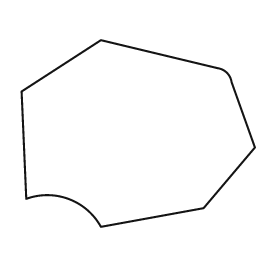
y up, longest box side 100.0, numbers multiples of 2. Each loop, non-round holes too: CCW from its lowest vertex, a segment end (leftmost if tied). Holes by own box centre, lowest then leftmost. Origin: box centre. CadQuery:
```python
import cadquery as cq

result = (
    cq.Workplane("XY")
    .moveTo(-16.0, -40.0)
    .lineTo(28.0, -32.0)
    .lineTo(50.0, -6.0)
    .lineTo(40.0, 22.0)
    .threePointArc((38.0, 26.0), (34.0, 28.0))
    .lineTo(-16.0, 40.0)
    .lineTo(-50.0, 18.0)
    .lineTo(-48.0, -28.0)
    .threePointArc((-30.0, -28.0), (-16.0, -40.0))
    .close()
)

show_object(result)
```